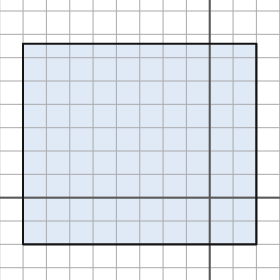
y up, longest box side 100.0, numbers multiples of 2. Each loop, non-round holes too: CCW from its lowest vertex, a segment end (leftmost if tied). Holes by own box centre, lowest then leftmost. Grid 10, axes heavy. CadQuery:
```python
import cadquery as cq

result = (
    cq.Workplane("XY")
    .moveTo(-80.0, -20.0)
    .lineTo(20.0, -20.0)
    .lineTo(20.0, 66.0)
    .lineTo(-80.0, 66.0)
    .close()
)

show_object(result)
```